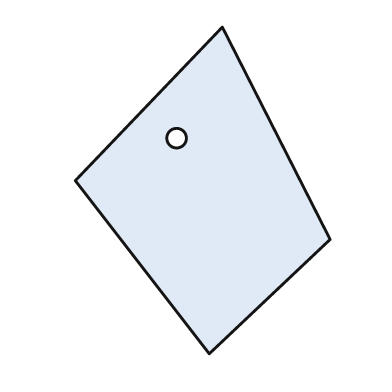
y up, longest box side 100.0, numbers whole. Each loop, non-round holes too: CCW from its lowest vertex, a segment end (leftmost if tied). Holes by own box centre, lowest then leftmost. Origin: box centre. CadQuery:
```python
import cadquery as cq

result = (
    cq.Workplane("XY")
    .moveTo(2.0, -50.0)
    .lineTo(39.0, -15.0)
    .lineTo(6.0, 50.0)
    .lineTo(-39.0, 3.0)
    .close()
    .moveTo(-8.0, 16.0)
    .circle(3.0)
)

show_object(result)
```